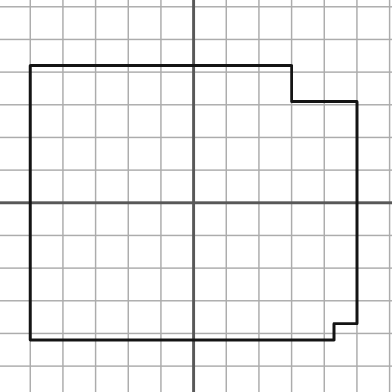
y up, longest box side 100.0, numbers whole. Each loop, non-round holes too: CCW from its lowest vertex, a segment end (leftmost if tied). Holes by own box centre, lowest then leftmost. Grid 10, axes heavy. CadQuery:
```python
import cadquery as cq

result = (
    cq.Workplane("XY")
    .moveTo(-50.0, -42.0)
    .lineTo(43.0, -42.0)
    .lineTo(43.0, -37.0)
    .lineTo(50.0, -37.0)
    .lineTo(50.0, 31.0)
    .lineTo(30.0, 31.0)
    .lineTo(30.0, 42.0)
    .lineTo(-50.0, 42.0)
    .close()
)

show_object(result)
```